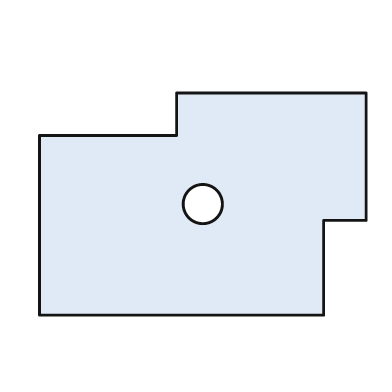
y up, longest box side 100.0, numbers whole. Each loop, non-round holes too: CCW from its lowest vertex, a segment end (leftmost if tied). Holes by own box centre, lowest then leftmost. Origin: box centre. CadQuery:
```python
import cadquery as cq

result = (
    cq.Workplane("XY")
    .moveTo(-50.0, -34.0)
    .lineTo(37.0, -34.0)
    .lineTo(37.0, -5.0)
    .lineTo(50.0, -5.0)
    .lineTo(50.0, 34.0)
    .lineTo(-8.0, 34.0)
    .lineTo(-8.0, 21.0)
    .lineTo(-50.0, 21.0)
    .close()
    .moveTo(0.0, 0.0)
    .circle(6.0)
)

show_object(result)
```